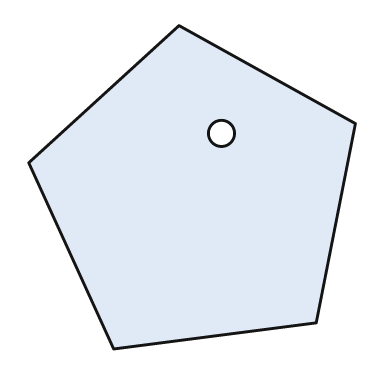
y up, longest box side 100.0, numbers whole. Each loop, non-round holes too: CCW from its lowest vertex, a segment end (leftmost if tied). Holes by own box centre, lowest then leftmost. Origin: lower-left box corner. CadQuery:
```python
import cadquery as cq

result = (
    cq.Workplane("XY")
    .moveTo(26.0, 0.0)
    .lineTo(88.0, 8.0)
    .lineTo(100.0, 69.0)
    .lineTo(46.0, 99.0)
    .lineTo(0.0, 57.0)
    .close()
    .moveTo(59.0, 66.0)
    .circle(4.0)
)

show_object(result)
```